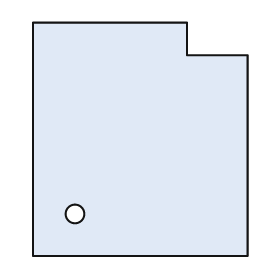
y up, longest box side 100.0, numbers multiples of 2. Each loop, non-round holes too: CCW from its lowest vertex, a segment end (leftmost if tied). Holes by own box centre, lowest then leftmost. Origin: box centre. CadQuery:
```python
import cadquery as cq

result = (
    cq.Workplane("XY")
    .moveTo(-46.0, -50.0)
    .lineTo(46.0, -50.0)
    .lineTo(46.0, 36.0)
    .lineTo(20.0, 36.0)
    .lineTo(20.0, 50.0)
    .lineTo(-46.0, 50.0)
    .close()
    .moveTo(-28.0, -32.0)
    .circle(4.0)
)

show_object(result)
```